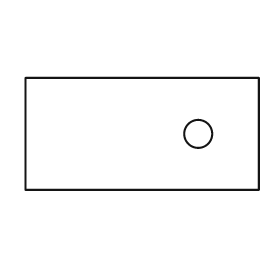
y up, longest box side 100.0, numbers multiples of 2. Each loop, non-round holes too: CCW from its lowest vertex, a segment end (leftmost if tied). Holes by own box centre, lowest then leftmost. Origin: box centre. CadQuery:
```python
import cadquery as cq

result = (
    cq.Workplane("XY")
    .moveTo(-50.0, -24.0)
    .lineTo(50.0, -24.0)
    .lineTo(50.0, 24.0)
    .lineTo(-50.0, 24.0)
    .close()
    .moveTo(24.0, 0.0)
    .circle(6.0)
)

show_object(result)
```